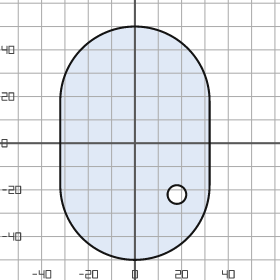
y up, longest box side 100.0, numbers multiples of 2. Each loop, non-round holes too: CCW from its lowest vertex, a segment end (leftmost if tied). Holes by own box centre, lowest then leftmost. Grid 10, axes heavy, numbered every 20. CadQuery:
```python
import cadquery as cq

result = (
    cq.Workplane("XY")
    .moveTo(-32.0, -18.0)
    .threePointArc((0.0, -50.0), (32.0, -18.0))
    .lineTo(32.0, 18.0)
    .threePointArc((0.0, 50.0), (-32.0, 18.0))
    .close()
    .moveTo(18.0, -22.0)
    .circle(4.0)
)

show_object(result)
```